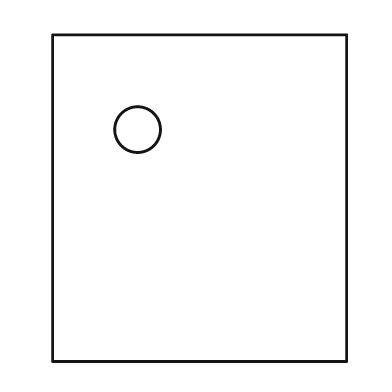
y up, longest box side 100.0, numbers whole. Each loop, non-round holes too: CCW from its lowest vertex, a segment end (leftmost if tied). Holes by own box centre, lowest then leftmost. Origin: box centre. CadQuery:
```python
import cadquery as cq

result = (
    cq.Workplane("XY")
    .moveTo(-45.0, -50.0)
    .lineTo(45.0, -50.0)
    .lineTo(45.0, 50.0)
    .lineTo(-45.0, 50.0)
    .close()
    .moveTo(-19.0, 21.0)
    .circle(7.0)
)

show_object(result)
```